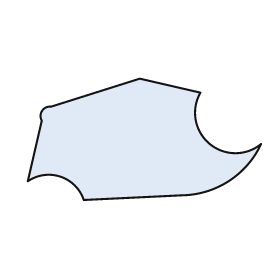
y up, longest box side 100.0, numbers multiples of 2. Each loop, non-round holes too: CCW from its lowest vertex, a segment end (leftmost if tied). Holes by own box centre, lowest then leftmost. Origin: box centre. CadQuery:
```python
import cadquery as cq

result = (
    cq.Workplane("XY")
    .moveTo(-26.0, -26.0)
    .lineTo(16.0, -24.0)
    .threePointArc((36.0, -18.0), (50.0, -2.0))
    .threePointArc((28.0, -2.0), (24.0, 20.0))
    .lineTo(-2.0, 26.0)
    .lineTo(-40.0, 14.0)
    .threePointArc((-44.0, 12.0), (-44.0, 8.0))
    .lineTo(-50.0, -18.0)
    .threePointArc((-36.0, -16.0), (-26.0, -26.0))
    .close()
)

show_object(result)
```